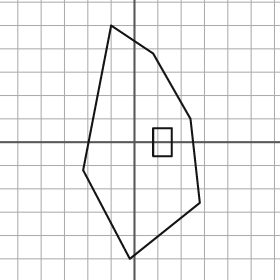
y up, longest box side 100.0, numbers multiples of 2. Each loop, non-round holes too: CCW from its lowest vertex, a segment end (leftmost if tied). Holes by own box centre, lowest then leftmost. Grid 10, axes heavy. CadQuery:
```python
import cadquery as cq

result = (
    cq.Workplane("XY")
    .moveTo(-2.0, -50.0)
    .lineTo(28.0, -26.0)
    .lineTo(24.0, 10.0)
    .lineTo(8.0, 38.0)
    .lineTo(-10.0, 50.0)
    .lineTo(-22.0, -12.0)
    .close()
    .moveTo(8.0, -6.0)
    .lineTo(16.0, -6.0)
    .lineTo(16.0, 6.0)
    .lineTo(8.0, 6.0)
    .close()
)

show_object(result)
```